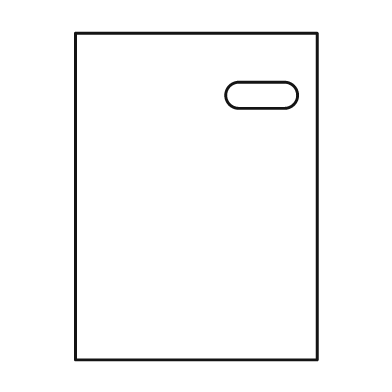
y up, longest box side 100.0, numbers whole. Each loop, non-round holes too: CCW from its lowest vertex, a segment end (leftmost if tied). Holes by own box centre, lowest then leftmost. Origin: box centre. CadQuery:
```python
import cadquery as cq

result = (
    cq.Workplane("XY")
    .moveTo(-37.0, -50.0)
    .lineTo(37.0, -50.0)
    .lineTo(37.0, 50.0)
    .lineTo(-37.0, 50.0)
    .close()
    .moveTo(13.0, 27.0)
    .lineTo(27.0, 27.0)
    .threePointArc((31.0, 31.0), (27.0, 35.0))
    .lineTo(13.0, 35.0)
    .threePointArc((9.0, 31.0), (13.0, 27.0))
    .close()
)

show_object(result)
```